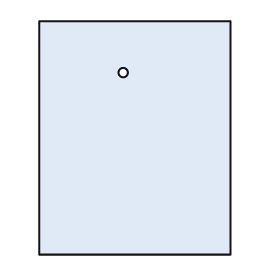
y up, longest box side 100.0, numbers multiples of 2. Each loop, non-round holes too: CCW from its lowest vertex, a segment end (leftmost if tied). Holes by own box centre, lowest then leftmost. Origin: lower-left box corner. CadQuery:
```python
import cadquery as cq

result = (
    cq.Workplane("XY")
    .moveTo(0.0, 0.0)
    .lineTo(82.0, 0.0)
    .lineTo(82.0, 100.0)
    .lineTo(0.0, 100.0)
    .close()
    .moveTo(36.0, 78.0)
    .circle(2.0)
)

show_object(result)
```